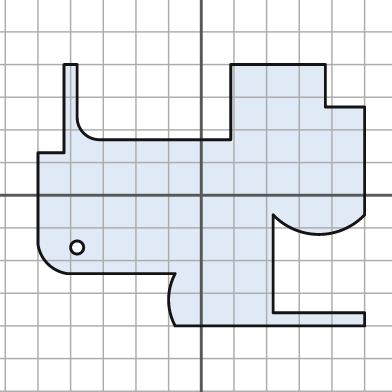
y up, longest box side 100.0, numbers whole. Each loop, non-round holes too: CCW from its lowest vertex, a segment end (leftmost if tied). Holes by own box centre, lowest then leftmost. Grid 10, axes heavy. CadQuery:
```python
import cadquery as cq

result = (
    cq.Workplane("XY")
    .moveTo(-8.0, -40.0)
    .lineTo(50.0, -40.0)
    .lineTo(50.0, -36.0)
    .lineTo(22.0, -36.0)
    .lineTo(22.0, -6.0)
    .threePointArc((36.0, -12.0), (50.0, -6.0))
    .lineTo(50.0, 27.0)
    .lineTo(38.0, 27.0)
    .lineTo(38.0, 40.0)
    .lineTo(9.0, 40.0)
    .lineTo(9.0, 17.0)
    .lineTo(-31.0, 17.0)
    .threePointArc((-36.0, 19.0), (-38.0, 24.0))
    .lineTo(-38.0, 40.0)
    .lineTo(-42.0, 40.0)
    .lineTo(-42.0, 13.0)
    .lineTo(-50.0, 13.0)
    .lineTo(-50.0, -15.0)
    .threePointArc((-47.0, -21.0), (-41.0, -24.0))
    .lineTo(-8.0, -24.0)
    .threePointArc((-10.0, -32.0), (-8.0, -40.0))
    .close()
    .moveTo(-38.0, -16.0)
    .circle(2.0)
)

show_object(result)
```